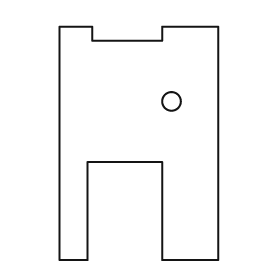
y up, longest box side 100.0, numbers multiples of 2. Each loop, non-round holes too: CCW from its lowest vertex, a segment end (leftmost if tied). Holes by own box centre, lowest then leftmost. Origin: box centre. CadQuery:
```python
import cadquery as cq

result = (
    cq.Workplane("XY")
    .moveTo(-34.0, -50.0)
    .lineTo(-22.0, -50.0)
    .lineTo(-22.0, -8.0)
    .lineTo(10.0, -8.0)
    .lineTo(10.0, -50.0)
    .lineTo(34.0, -50.0)
    .lineTo(34.0, 50.0)
    .lineTo(10.0, 50.0)
    .lineTo(10.0, 44.0)
    .lineTo(-20.0, 44.0)
    .lineTo(-20.0, 50.0)
    .lineTo(-34.0, 50.0)
    .close()
    .moveTo(14.0, 18.0)
    .circle(4.0)
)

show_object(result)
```